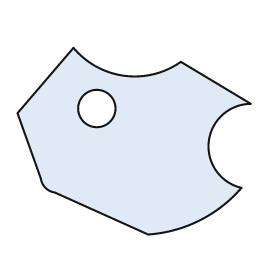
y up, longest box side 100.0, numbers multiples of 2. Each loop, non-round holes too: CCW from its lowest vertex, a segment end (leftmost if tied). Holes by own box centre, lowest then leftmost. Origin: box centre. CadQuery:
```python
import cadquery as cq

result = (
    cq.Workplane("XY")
    .moveTo(6.0, -40.0)
    .threePointArc((28.0, -34.0), (46.0, -20.0))
    .threePointArc((32.0, 0.0), (50.0, 16.0))
    .lineTo(20.0, 34.0)
    .threePointArc((-4.0, 28.0), (-26.0, 40.0))
    .lineTo(-50.0, 12.0)
    .lineTo(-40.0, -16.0)
    .threePointArc((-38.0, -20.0), (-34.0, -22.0))
    .close()
    .moveTo(-16.0, 14.0)
    .circle(8.0)
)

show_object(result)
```